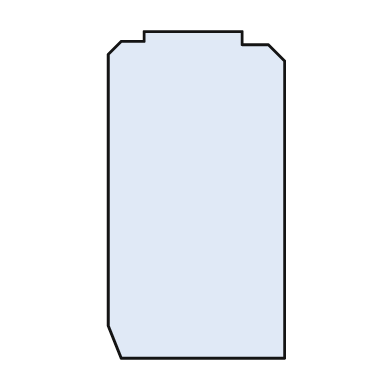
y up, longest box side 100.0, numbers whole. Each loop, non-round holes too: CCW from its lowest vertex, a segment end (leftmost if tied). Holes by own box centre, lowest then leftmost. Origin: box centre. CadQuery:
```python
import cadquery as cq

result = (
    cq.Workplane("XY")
    .moveTo(-23.0, -50.0)
    .lineTo(27.0, -50.0)
    .lineTo(27.0, 41.0)
    .lineTo(22.0, 46.0)
    .lineTo(14.0, 46.0)
    .lineTo(14.0, 50.0)
    .lineTo(-16.0, 50.0)
    .lineTo(-16.0, 47.0)
    .lineTo(-23.0, 47.0)
    .lineTo(-27.0, 43.0)
    .lineTo(-27.0, -40.0)
    .close()
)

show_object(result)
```